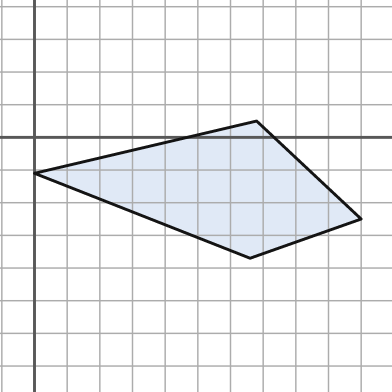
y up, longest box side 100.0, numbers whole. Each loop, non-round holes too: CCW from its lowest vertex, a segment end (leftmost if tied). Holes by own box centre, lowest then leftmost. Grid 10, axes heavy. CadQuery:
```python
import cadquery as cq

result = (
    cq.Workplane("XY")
    .moveTo(66.0, -37.0)
    .lineTo(100.0, -25.0)
    .lineTo(68.0, 5.0)
    .lineTo(0.0, -11.0)
    .close()
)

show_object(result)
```